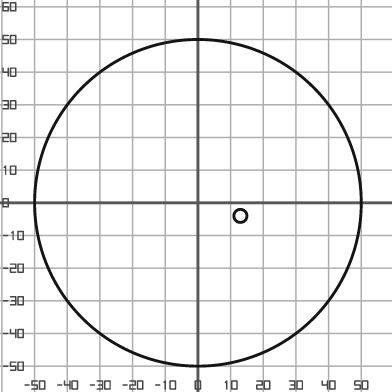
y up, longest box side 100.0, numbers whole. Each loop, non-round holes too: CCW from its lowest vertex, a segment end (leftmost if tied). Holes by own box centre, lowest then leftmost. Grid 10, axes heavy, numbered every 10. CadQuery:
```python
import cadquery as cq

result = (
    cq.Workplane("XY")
    .moveTo(0.0, 0.0)
    .circle(50.0)
    .moveTo(13.0, -4.0)
    .circle(2.0)
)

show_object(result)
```